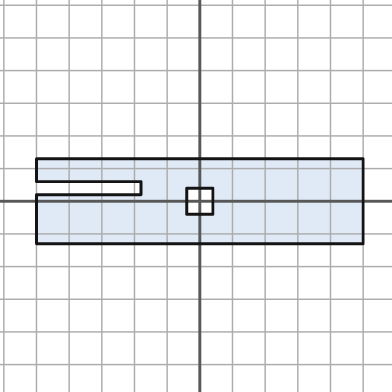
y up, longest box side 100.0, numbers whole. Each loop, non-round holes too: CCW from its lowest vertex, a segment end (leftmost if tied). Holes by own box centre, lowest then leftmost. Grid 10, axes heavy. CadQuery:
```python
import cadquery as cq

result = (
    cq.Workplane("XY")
    .moveTo(-50.0, -13.0)
    .lineTo(50.0, -13.0)
    .lineTo(50.0, 13.0)
    .lineTo(-50.0, 13.0)
    .lineTo(-50.0, 6.0)
    .lineTo(-18.0, 6.0)
    .lineTo(-18.0, 2.0)
    .lineTo(-50.0, 2.0)
    .close()
    .moveTo(-4.0, -4.0)
    .lineTo(4.0, -4.0)
    .lineTo(4.0, 4.0)
    .lineTo(-4.0, 4.0)
    .close()
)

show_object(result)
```